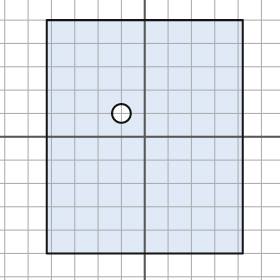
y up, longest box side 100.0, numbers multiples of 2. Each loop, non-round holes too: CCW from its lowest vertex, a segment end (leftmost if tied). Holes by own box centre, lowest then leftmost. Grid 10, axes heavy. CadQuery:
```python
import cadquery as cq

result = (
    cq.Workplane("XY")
    .moveTo(-42.0, -50.0)
    .lineTo(42.0, -50.0)
    .lineTo(42.0, 50.0)
    .lineTo(-42.0, 50.0)
    .close()
    .moveTo(-10.0, 10.0)
    .circle(4.0)
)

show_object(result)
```